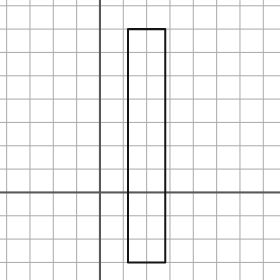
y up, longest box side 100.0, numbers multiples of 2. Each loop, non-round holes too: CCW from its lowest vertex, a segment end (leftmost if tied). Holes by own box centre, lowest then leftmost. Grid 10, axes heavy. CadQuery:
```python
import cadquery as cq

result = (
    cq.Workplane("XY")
    .moveTo(12.0, -30.0)
    .lineTo(28.0, -30.0)
    .lineTo(28.0, 70.0)
    .lineTo(12.0, 70.0)
    .close()
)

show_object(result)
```